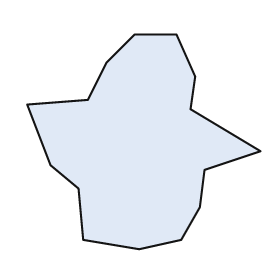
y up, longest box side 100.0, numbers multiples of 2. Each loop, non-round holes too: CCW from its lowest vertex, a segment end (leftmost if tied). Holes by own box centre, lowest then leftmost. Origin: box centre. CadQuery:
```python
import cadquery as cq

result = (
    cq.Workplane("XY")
    .moveTo(-2.0, -46.0)
    .lineTo(16.0, -42.0)
    .lineTo(24.0, -28.0)
    .lineTo(26.0, -12.0)
    .lineTo(50.0, -4.0)
    .lineTo(20.0, 14.0)
    .lineTo(22.0, 28.0)
    .lineTo(14.0, 46.0)
    .lineTo(-4.0, 46.0)
    .lineTo(-16.0, 34.0)
    .lineTo(-24.0, 18.0)
    .lineTo(-50.0, 16.0)
    .lineTo(-40.0, -10.0)
    .lineTo(-28.0, -20.0)
    .lineTo(-26.0, -42.0)
    .close()
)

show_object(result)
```